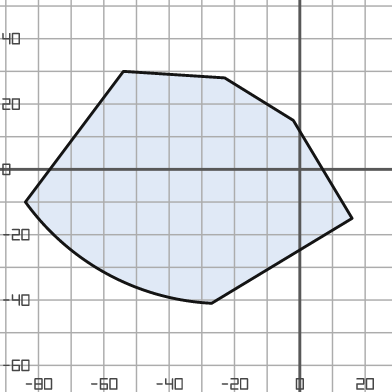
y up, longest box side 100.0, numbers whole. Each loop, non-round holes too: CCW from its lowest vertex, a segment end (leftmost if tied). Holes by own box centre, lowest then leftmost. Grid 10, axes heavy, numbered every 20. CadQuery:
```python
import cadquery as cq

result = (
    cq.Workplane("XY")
    .moveTo(-27.0, -41.0)
    .lineTo(16.0, -15.0)
    .lineTo(-2.0, 15.0)
    .lineTo(-23.0, 28.0)
    .lineTo(-54.0, 30.0)
    .lineTo(-84.0, -10.0)
    .threePointArc((-59.0, -32.0), (-27.0, -41.0))
    .close()
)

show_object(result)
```